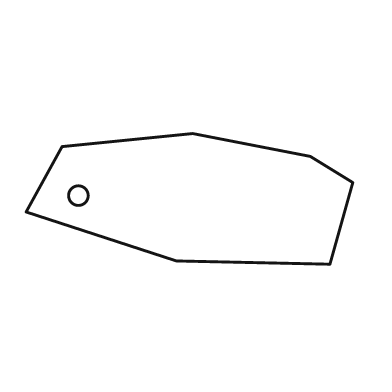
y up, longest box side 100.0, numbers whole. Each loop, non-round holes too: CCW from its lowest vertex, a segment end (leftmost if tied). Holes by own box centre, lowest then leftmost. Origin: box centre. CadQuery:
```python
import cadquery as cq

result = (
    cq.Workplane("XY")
    .moveTo(43.0, -20.0)
    .lineTo(50.0, 5.0)
    .lineTo(37.0, 13.0)
    .lineTo(1.0, 20.0)
    .lineTo(-39.0, 16.0)
    .lineTo(-50.0, -4.0)
    .lineTo(-4.0, -19.0)
    .close()
    .moveTo(-34.0, 1.0)
    .circle(3.0)
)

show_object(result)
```